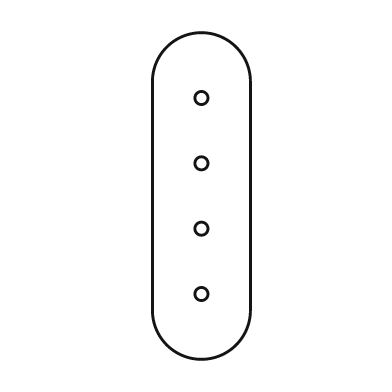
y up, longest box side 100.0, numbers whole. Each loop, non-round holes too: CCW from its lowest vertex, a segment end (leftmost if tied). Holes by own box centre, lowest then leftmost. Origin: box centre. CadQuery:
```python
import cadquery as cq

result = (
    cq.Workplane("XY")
    .moveTo(-15.0, -35.0)
    .threePointArc((0.0, -50.0), (15.0, -35.0))
    .lineTo(15.0, 35.0)
    .threePointArc((0.0, 50.0), (-15.0, 35.0))
    .close()
    .moveTo(0.0, -30.0)
    .circle(2.0)
    .moveTo(0.0, -10.0)
    .circle(2.0)
    .moveTo(0.0, 10.0)
    .circle(2.0)
    .moveTo(0.0, 30.0)
    .circle(2.0)
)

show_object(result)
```